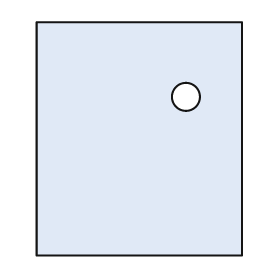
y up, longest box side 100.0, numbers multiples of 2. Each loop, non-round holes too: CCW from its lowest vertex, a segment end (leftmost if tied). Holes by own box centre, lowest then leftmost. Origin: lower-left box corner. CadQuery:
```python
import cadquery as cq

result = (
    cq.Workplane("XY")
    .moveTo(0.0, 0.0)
    .lineTo(88.0, 0.0)
    .lineTo(88.0, 100.0)
    .lineTo(0.0, 100.0)
    .close()
    .moveTo(64.0, 68.0)
    .circle(6.0)
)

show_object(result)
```